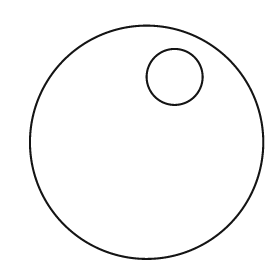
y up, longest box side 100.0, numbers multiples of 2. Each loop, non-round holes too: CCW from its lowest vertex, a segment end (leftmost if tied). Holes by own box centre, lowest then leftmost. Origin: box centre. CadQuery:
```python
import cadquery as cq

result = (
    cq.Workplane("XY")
    .moveTo(0.0, 0.0)
    .circle(50.0)
    .moveTo(12.0, 28.0)
    .circle(12.0)
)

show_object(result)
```